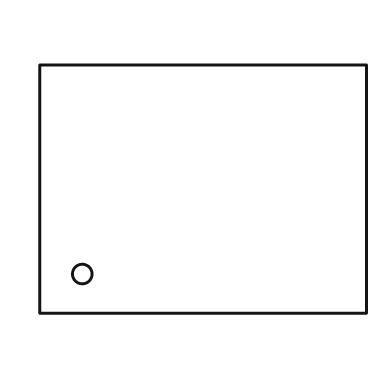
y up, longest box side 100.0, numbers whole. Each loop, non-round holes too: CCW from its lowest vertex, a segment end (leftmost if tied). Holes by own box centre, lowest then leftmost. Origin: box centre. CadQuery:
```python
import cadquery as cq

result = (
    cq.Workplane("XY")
    .moveTo(-50.0, -38.0)
    .lineTo(50.0, -38.0)
    .lineTo(50.0, 38.0)
    .lineTo(-50.0, 38.0)
    .close()
    .moveTo(-37.0, -26.0)
    .circle(3.0)
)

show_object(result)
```